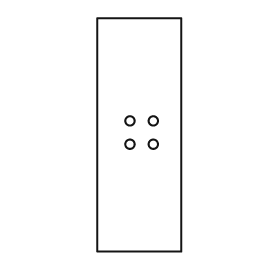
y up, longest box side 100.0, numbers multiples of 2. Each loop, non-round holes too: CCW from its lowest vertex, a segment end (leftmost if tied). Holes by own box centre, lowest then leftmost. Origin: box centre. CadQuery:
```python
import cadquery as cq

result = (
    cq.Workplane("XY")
    .moveTo(-18.0, -50.0)
    .lineTo(18.0, -50.0)
    .lineTo(18.0, 50.0)
    .lineTo(-18.0, 50.0)
    .close()
    .moveTo(-4.0, -4.0)
    .circle(2.0)
    .moveTo(6.0, -4.0)
    .circle(2.0)
    .moveTo(-4.0, 6.0)
    .circle(2.0)
    .moveTo(6.0, 6.0)
    .circle(2.0)
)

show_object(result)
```